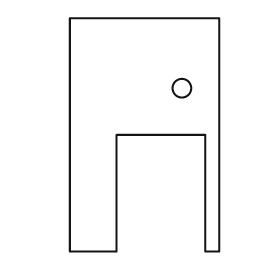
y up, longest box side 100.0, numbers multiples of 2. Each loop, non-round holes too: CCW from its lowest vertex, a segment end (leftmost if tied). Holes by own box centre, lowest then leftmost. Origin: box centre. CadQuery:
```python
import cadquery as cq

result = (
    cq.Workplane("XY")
    .moveTo(-32.0, -50.0)
    .lineTo(-12.0, -50.0)
    .lineTo(-12.0, 0.0)
    .lineTo(26.0, 0.0)
    .lineTo(26.0, -50.0)
    .lineTo(32.0, -50.0)
    .lineTo(32.0, 50.0)
    .lineTo(-32.0, 50.0)
    .close()
    .moveTo(16.0, 20.0)
    .circle(4.0)
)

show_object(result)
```